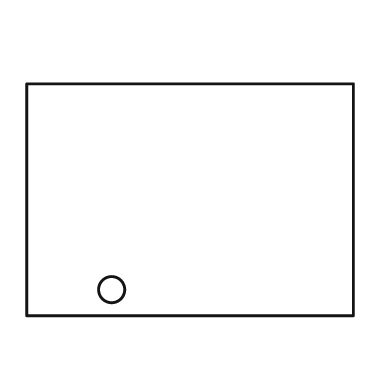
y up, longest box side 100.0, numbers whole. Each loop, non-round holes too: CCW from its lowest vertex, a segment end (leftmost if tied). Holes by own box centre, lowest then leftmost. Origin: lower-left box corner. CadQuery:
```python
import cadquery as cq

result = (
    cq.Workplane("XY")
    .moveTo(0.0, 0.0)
    .lineTo(100.0, 0.0)
    .lineTo(100.0, 71.0)
    .lineTo(0.0, 71.0)
    .close()
    .moveTo(26.0, 8.0)
    .circle(4.0)
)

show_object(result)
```